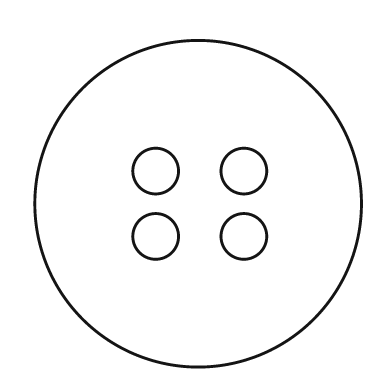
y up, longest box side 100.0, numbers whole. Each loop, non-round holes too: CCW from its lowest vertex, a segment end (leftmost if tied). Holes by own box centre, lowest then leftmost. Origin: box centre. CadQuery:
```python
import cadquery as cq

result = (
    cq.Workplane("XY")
    .moveTo(0.0, 0.0)
    .circle(50.0)
    .moveTo(-13.0, -10.0)
    .circle(7.0)
    .moveTo(14.0, -10.0)
    .circle(7.0)
    .moveTo(-13.0, 10.0)
    .circle(7.0)
    .moveTo(14.0, 10.0)
    .circle(7.0)
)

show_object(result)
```